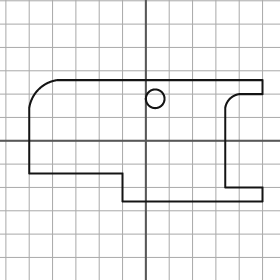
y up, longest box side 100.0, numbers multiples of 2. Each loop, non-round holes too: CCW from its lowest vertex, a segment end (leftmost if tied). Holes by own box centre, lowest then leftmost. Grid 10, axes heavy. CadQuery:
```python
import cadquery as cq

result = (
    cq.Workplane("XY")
    .moveTo(-10.0, -26.0)
    .lineTo(50.0, -26.0)
    .lineTo(50.0, -20.0)
    .lineTo(34.0, -20.0)
    .lineTo(34.0, 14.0)
    .threePointArc((36.0, 18.0), (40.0, 20.0))
    .lineTo(50.0, 20.0)
    .lineTo(50.0, 26.0)
    .lineTo(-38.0, 26.0)
    .threePointArc((-46.0, 22.0), (-50.0, 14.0))
    .lineTo(-50.0, -14.0)
    .lineTo(-10.0, -14.0)
    .close()
    .moveTo(4.0, 18.0)
    .circle(4.0)
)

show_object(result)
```